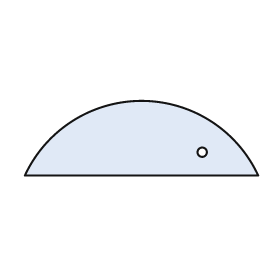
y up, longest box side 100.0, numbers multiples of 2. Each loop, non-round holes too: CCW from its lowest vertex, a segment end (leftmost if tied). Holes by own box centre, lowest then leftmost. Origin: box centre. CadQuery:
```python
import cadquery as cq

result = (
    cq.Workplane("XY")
    .moveTo(-50.0, -16.0)
    .lineTo(50.0, -16.0)
    .threePointArc((0.0, 16.0), (-50.0, -16.0))
    .close()
    .moveTo(26.0, -6.0)
    .circle(2.0)
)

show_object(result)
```